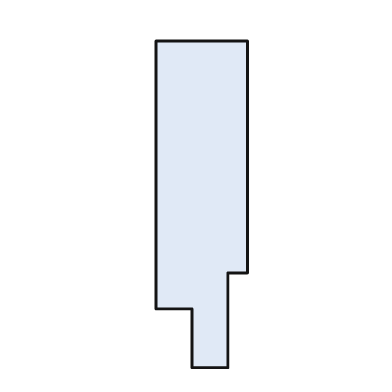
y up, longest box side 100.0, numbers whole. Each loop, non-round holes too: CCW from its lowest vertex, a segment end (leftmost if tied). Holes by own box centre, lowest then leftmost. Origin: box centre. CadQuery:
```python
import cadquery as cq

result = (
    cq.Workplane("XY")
    .moveTo(-3.0, -50.0)
    .lineTo(8.0, -50.0)
    .lineTo(8.0, -21.0)
    .lineTo(14.0, -21.0)
    .lineTo(14.0, 50.0)
    .lineTo(-14.0, 50.0)
    .lineTo(-14.0, -32.0)
    .lineTo(-3.0, -32.0)
    .close()
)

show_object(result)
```